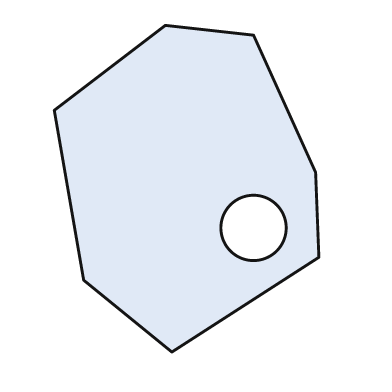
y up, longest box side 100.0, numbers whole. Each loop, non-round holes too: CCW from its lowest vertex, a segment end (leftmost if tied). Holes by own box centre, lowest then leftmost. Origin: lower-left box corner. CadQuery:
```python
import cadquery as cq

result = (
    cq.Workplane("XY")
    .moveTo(36.0, 0.0)
    .lineTo(81.0, 29.0)
    .lineTo(80.0, 55.0)
    .lineTo(61.0, 97.0)
    .lineTo(34.0, 100.0)
    .lineTo(0.0, 74.0)
    .lineTo(9.0, 22.0)
    .close()
    .moveTo(61.0, 38.0)
    .circle(10.0)
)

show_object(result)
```